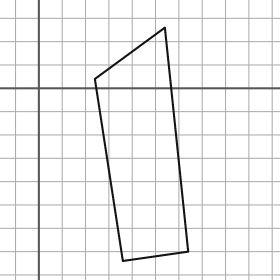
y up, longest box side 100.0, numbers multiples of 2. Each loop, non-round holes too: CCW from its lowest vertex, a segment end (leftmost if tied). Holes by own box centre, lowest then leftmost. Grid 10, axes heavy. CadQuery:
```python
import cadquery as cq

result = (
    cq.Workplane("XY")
    .moveTo(36.0, -74.0)
    .lineTo(64.0, -70.0)
    .lineTo(54.0, 26.0)
    .lineTo(24.0, 4.0)
    .close()
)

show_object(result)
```